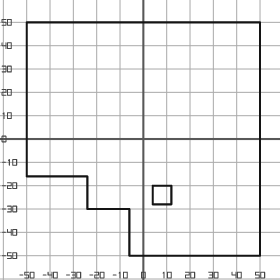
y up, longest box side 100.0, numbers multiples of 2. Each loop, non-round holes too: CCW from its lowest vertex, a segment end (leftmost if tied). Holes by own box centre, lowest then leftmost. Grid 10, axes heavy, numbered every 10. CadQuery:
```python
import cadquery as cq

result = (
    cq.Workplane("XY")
    .moveTo(-6.0, -50.0)
    .lineTo(50.0, -50.0)
    .lineTo(50.0, 50.0)
    .lineTo(-50.0, 50.0)
    .lineTo(-50.0, -16.0)
    .lineTo(-24.0, -16.0)
    .lineTo(-24.0, -30.0)
    .lineTo(-6.0, -30.0)
    .close()
    .moveTo(4.0, -28.0)
    .lineTo(12.0, -28.0)
    .lineTo(12.0, -20.0)
    .lineTo(4.0, -20.0)
    .close()
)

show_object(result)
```